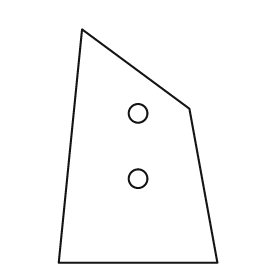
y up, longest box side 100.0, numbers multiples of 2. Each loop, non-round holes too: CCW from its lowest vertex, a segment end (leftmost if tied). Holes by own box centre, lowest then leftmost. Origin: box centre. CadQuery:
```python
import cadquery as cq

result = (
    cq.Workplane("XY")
    .moveTo(-34.0, -50.0)
    .lineTo(34.0, -50.0)
    .lineTo(22.0, 16.0)
    .lineTo(-24.0, 50.0)
    .close()
    .moveTo(0.0, -14.0)
    .circle(4.0)
    .moveTo(0.0, 14.0)
    .circle(4.0)
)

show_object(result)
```